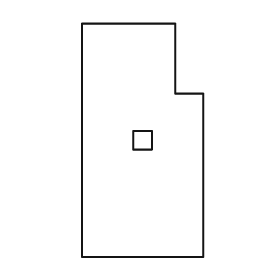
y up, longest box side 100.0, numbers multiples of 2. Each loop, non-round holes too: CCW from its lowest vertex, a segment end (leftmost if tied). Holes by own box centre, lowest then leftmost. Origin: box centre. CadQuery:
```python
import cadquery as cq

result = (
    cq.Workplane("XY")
    .moveTo(-26.0, -50.0)
    .lineTo(26.0, -50.0)
    .lineTo(26.0, 20.0)
    .lineTo(14.0, 20.0)
    .lineTo(14.0, 50.0)
    .lineTo(-26.0, 50.0)
    .close()
    .moveTo(-4.0, -4.0)
    .lineTo(4.0, -4.0)
    .lineTo(4.0, 4.0)
    .lineTo(-4.0, 4.0)
    .close()
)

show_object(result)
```